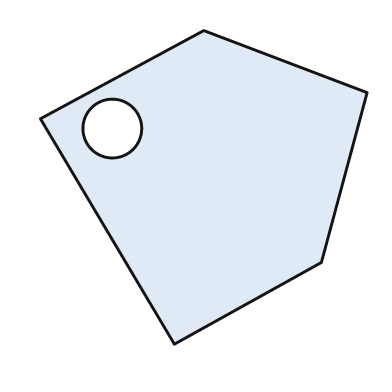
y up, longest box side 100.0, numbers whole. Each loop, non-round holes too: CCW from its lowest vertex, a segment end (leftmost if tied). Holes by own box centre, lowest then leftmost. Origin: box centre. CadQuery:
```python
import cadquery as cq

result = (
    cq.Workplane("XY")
    .moveTo(-9.0, -48.0)
    .lineTo(36.0, -23.0)
    .lineTo(50.0, 29.0)
    .lineTo(0.0, 48.0)
    .lineTo(-50.0, 21.0)
    .close()
    .moveTo(-28.0, 18.0)
    .circle(9.0)
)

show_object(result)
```